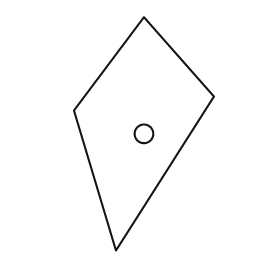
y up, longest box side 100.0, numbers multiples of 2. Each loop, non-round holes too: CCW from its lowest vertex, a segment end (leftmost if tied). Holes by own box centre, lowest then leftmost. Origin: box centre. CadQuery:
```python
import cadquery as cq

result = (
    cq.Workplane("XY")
    .moveTo(-12.0, -50.0)
    .lineTo(30.0, 16.0)
    .lineTo(0.0, 50.0)
    .lineTo(-30.0, 10.0)
    .close()
    .moveTo(0.0, 0.0)
    .circle(4.0)
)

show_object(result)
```